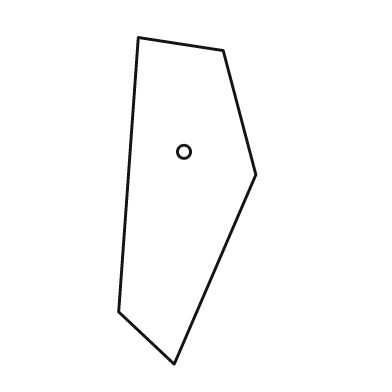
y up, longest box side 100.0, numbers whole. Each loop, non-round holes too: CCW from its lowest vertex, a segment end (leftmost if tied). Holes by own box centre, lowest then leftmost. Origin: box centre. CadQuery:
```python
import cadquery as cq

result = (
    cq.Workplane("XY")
    .moveTo(-4.0, -50.0)
    .lineTo(21.0, 8.0)
    .lineTo(11.0, 46.0)
    .lineTo(-15.0, 50.0)
    .lineTo(-21.0, -34.0)
    .close()
    .moveTo(-1.0, 15.0)
    .circle(2.0)
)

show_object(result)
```